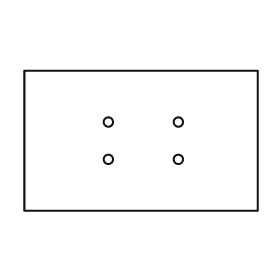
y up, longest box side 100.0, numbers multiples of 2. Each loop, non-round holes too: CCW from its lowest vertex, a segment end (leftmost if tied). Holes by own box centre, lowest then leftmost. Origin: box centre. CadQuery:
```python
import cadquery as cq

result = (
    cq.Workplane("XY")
    .moveTo(-50.0, -30.0)
    .lineTo(50.0, -30.0)
    .lineTo(50.0, 30.0)
    .lineTo(-50.0, 30.0)
    .close()
    .moveTo(-14.0, -8.0)
    .circle(2.0)
    .moveTo(16.0, -8.0)
    .circle(2.0)
    .moveTo(-14.0, 8.0)
    .circle(2.0)
    .moveTo(16.0, 8.0)
    .circle(2.0)
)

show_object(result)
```